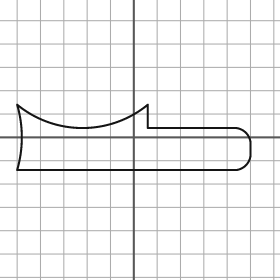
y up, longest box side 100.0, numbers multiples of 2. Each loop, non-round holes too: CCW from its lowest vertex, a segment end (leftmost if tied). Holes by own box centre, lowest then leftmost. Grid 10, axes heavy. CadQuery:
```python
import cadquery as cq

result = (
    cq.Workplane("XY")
    .moveTo(-50.0, -14.0)
    .lineTo(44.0, -14.0)
    .threePointArc((48.0, -12.0), (50.0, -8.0))
    .lineTo(50.0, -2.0)
    .threePointArc((48.0, 2.0), (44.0, 4.0))
    .lineTo(6.0, 4.0)
    .lineTo(6.0, 14.0)
    .threePointArc((-22.0, 4.0), (-50.0, 14.0))
    .threePointArc((-48.0, 0.0), (-50.0, -14.0))
    .close()
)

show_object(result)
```